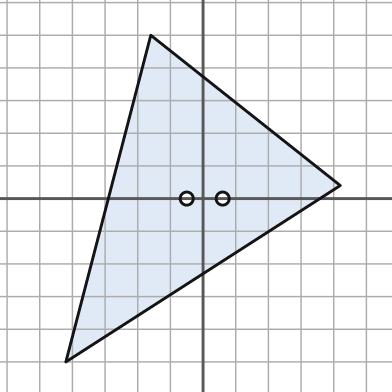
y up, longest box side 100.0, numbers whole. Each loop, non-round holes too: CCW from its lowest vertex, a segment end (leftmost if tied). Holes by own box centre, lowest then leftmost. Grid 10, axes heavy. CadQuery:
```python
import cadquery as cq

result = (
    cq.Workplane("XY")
    .moveTo(-42.0, -50.0)
    .lineTo(42.0, 4.0)
    .lineTo(-16.0, 50.0)
    .close()
    .moveTo(-5.0, 0.0)
    .circle(2.0)
    .moveTo(6.0, 0.0)
    .circle(2.0)
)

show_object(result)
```